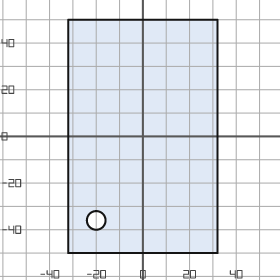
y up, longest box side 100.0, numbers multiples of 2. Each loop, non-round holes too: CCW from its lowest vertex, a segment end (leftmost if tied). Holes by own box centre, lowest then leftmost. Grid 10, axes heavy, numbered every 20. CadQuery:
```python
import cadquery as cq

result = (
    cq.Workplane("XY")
    .moveTo(-32.0, -50.0)
    .lineTo(32.0, -50.0)
    .lineTo(32.0, 50.0)
    .lineTo(-32.0, 50.0)
    .close()
    .moveTo(-20.0, -36.0)
    .circle(4.0)
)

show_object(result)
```